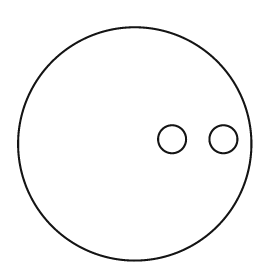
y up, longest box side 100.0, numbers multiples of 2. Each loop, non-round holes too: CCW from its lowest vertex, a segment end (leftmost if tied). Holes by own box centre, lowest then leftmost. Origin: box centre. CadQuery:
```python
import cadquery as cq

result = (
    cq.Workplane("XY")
    .moveTo(0.0, 0.0)
    .circle(50.0)
    .moveTo(16.0, 2.0)
    .circle(6.0)
    .moveTo(38.0, 2.0)
    .circle(6.0)
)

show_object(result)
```